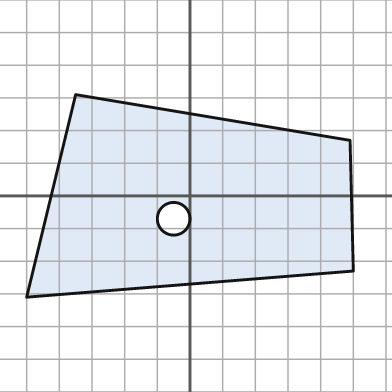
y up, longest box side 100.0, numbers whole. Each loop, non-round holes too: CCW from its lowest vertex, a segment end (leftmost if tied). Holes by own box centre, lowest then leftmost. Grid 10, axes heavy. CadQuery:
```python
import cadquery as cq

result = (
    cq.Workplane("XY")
    .moveTo(-50.0, -31.0)
    .lineTo(50.0, -23.0)
    .lineTo(49.0, 17.0)
    .lineTo(-35.0, 31.0)
    .close()
    .moveTo(-5.0, -7.0)
    .circle(5.0)
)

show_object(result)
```